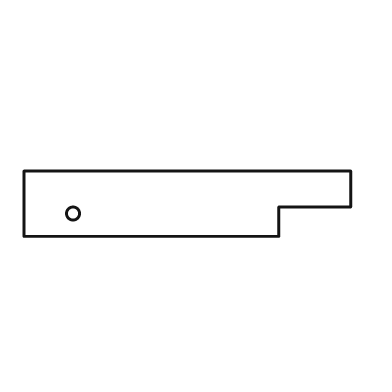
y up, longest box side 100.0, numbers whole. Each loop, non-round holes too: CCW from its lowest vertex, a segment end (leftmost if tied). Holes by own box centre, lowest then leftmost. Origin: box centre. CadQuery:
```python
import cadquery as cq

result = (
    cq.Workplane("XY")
    .moveTo(-50.0, -10.0)
    .lineTo(28.0, -10.0)
    .lineTo(28.0, -1.0)
    .lineTo(50.0, -1.0)
    .lineTo(50.0, 10.0)
    .lineTo(-50.0, 10.0)
    .close()
    .moveTo(-35.0, -3.0)
    .circle(2.0)
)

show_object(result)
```